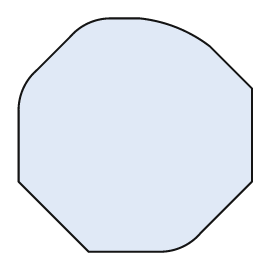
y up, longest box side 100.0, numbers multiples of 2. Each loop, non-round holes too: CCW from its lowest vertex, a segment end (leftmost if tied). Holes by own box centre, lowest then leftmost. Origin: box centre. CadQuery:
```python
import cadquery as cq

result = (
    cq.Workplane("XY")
    .moveTo(-20.0, -50.0)
    .lineTo(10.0, -50.0)
    .threePointArc((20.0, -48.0), (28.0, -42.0))
    .lineTo(50.0, -20.0)
    .lineTo(50.0, 20.0)
    .lineTo(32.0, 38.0)
    .threePointArc((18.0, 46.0), (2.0, 50.0))
    .lineTo(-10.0, 50.0)
    .threePointArc((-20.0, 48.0), (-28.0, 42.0))
    .lineTo(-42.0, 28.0)
    .threePointArc((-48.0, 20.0), (-50.0, 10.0))
    .lineTo(-50.0, -20.0)
    .close()
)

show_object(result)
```